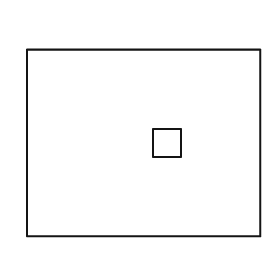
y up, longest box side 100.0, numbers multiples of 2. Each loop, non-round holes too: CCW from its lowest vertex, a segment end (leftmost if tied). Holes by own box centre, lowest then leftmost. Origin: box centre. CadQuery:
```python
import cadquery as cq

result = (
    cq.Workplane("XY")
    .moveTo(-50.0, -40.0)
    .lineTo(50.0, -40.0)
    .lineTo(50.0, 40.0)
    .lineTo(-50.0, 40.0)
    .close()
    .moveTo(4.0, -6.0)
    .lineTo(16.0, -6.0)
    .lineTo(16.0, 6.0)
    .lineTo(4.0, 6.0)
    .close()
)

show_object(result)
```